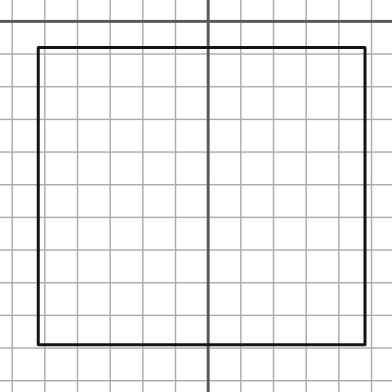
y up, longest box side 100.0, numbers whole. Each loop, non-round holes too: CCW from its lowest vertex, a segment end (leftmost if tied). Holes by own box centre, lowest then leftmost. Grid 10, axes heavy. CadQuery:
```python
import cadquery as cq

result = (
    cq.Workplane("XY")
    .moveTo(-52.0, -99.0)
    .lineTo(48.0, -99.0)
    .lineTo(48.0, -8.0)
    .lineTo(-52.0, -8.0)
    .close()
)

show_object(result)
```